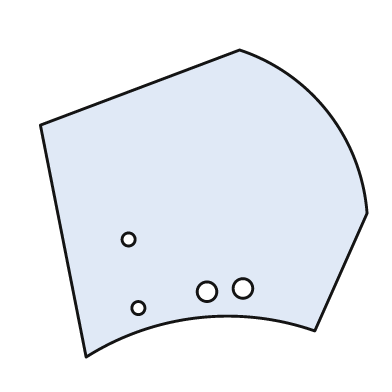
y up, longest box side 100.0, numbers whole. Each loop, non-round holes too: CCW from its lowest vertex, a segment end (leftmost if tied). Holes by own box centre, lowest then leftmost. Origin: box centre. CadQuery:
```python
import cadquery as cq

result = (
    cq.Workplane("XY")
    .moveTo(-36.0, -47.0)
    .threePointArc((-2.0, -35.0), (34.0, -39.0))
    .lineTo(50.0, -3.0)
    .threePointArc((38.0, 28.0), (11.0, 47.0))
    .lineTo(-50.0, 24.0)
    .close()
    .moveTo(-20.0, -32.0)
    .circle(2.0)
    .moveTo(1.0, -27.0)
    .circle(3.0)
    .moveTo(12.0, -26.0)
    .circle(3.0)
    .moveTo(-23.0, -11.0)
    .circle(2.0)
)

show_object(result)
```